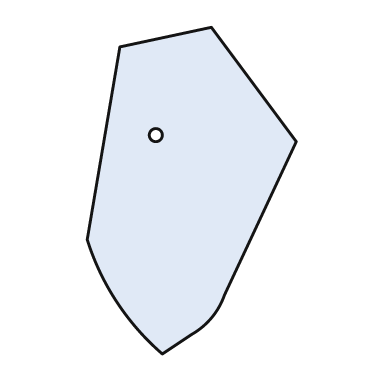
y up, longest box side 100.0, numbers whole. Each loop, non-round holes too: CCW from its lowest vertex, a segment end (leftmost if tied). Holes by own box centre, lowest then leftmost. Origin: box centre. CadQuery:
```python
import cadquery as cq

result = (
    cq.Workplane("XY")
    .moveTo(-9.0, -50.0)
    .lineTo(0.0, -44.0)
    .threePointArc((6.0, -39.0), (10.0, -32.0))
    .lineTo(32.0, 15.0)
    .lineTo(6.0, 50.0)
    .lineTo(-22.0, 44.0)
    .lineTo(-32.0, -15.0)
    .threePointArc((-23.0, -34.0), (-9.0, -50.0))
    .close()
    .moveTo(-11.0, 17.0)
    .circle(2.0)
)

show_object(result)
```